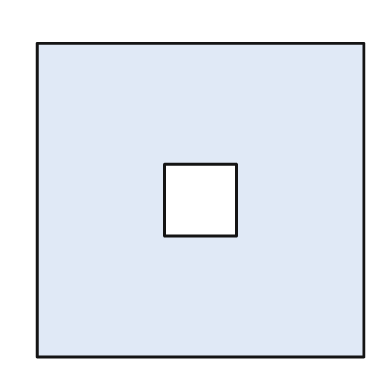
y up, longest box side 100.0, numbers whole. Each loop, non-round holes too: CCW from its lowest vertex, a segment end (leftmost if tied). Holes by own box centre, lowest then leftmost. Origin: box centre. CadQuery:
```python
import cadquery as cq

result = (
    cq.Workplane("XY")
    .moveTo(-50.0, -48.0)
    .lineTo(50.0, -48.0)
    .lineTo(50.0, 48.0)
    .lineTo(-50.0, 48.0)
    .close()
    .moveTo(-11.0, -11.0)
    .lineTo(11.0, -11.0)
    .lineTo(11.0, 11.0)
    .lineTo(-11.0, 11.0)
    .close()
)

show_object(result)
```